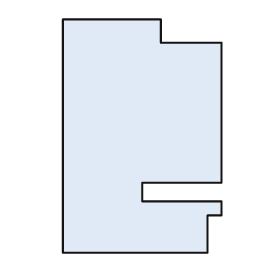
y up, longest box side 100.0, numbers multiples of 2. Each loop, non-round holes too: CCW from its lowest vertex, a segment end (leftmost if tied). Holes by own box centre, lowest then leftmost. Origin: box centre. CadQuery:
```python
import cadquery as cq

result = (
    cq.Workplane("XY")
    .moveTo(-34.0, -50.0)
    .lineTo(28.0, -50.0)
    .lineTo(28.0, -34.0)
    .lineTo(34.0, -34.0)
    .lineTo(34.0, -28.0)
    .lineTo(0.0, -28.0)
    .lineTo(0.0, -20.0)
    .lineTo(34.0, -20.0)
    .lineTo(34.0, 40.0)
    .lineTo(8.0, 40.0)
    .lineTo(8.0, 50.0)
    .lineTo(-34.0, 50.0)
    .close()
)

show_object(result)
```